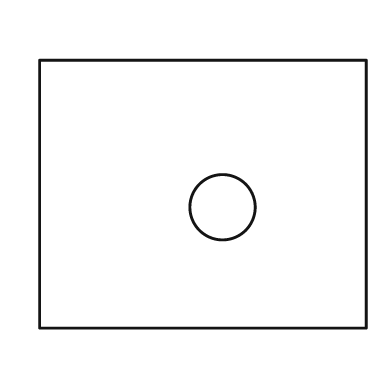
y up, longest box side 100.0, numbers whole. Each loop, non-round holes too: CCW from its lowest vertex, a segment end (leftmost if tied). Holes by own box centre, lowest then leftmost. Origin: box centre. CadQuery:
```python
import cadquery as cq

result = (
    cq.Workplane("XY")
    .moveTo(-50.0, -41.0)
    .lineTo(50.0, -41.0)
    .lineTo(50.0, 41.0)
    .lineTo(-50.0, 41.0)
    .close()
    .moveTo(6.0, -4.0)
    .circle(10.0)
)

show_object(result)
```